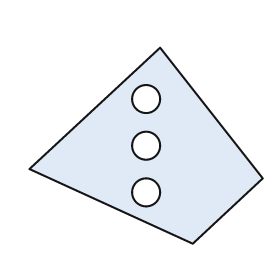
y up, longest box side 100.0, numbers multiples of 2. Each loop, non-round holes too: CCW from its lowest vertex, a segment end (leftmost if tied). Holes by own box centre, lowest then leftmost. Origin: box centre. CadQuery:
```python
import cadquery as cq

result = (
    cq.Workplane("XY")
    .moveTo(20.0, -42.0)
    .lineTo(50.0, -14.0)
    .lineTo(6.0, 42.0)
    .lineTo(-50.0, -10.0)
    .close()
    .moveTo(0.0, -20.0)
    .circle(6.0)
    .moveTo(0.0, 0.0)
    .circle(6.0)
    .moveTo(0.0, 20.0)
    .circle(6.0)
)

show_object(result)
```